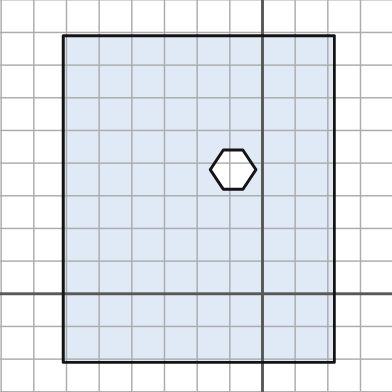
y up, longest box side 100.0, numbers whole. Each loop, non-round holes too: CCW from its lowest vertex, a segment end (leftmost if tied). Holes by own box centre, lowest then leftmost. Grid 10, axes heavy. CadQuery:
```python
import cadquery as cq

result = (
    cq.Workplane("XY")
    .moveTo(-61.0, -21.0)
    .lineTo(22.0, -21.0)
    .lineTo(22.0, 79.0)
    .lineTo(-61.0, 79.0)
    .close()
    .moveTo(-12.0, 32.0)
    .lineTo(-6.0, 32.0)
    .lineTo(-2.0, 38.0)
    .lineTo(-6.0, 44.0)
    .lineTo(-12.0, 44.0)
    .lineTo(-16.0, 38.0)
    .close()
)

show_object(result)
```